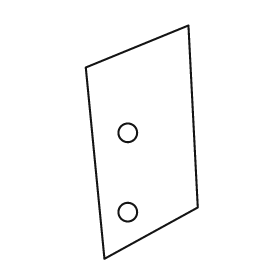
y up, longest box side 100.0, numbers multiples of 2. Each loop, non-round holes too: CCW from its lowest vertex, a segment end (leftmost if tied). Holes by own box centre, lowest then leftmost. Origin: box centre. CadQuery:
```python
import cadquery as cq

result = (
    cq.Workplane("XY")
    .moveTo(-16.0, -50.0)
    .lineTo(24.0, -28.0)
    .lineTo(20.0, 50.0)
    .lineTo(-24.0, 32.0)
    .close()
    .moveTo(-6.0, -30.0)
    .circle(4.0)
    .moveTo(-6.0, 4.0)
    .circle(4.0)
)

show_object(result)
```